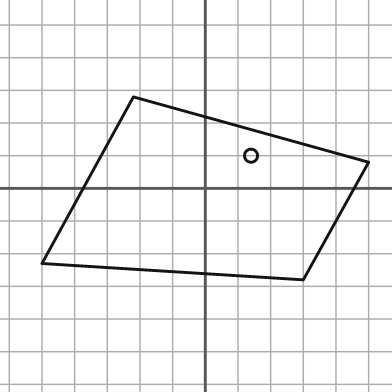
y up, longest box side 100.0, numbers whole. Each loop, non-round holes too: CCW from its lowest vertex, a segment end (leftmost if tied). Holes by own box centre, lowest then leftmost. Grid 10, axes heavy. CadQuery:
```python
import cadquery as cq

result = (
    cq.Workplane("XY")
    .moveTo(30.0, -28.0)
    .lineTo(50.0, 8.0)
    .lineTo(-22.0, 28.0)
    .lineTo(-50.0, -23.0)
    .close()
    .moveTo(14.0, 10.0)
    .circle(2.0)
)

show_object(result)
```